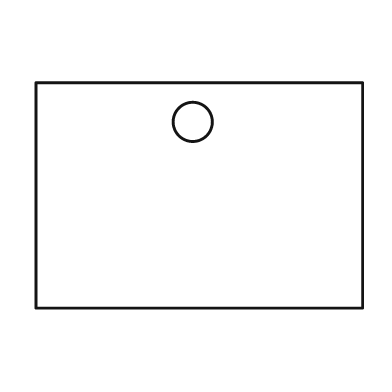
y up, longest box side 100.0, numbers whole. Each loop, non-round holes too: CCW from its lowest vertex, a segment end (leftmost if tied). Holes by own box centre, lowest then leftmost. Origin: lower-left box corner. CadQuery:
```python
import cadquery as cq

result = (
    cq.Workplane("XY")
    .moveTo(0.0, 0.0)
    .lineTo(100.0, 0.0)
    .lineTo(100.0, 69.0)
    .lineTo(0.0, 69.0)
    .close()
    .moveTo(48.0, 57.0)
    .circle(6.0)
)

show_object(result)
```